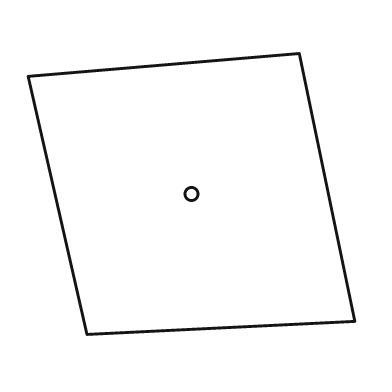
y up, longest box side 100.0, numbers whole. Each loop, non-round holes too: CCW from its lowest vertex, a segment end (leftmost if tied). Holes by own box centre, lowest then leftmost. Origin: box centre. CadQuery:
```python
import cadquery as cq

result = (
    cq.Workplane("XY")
    .moveTo(-32.0, -43.0)
    .lineTo(50.0, -39.0)
    .lineTo(33.0, 43.0)
    .lineTo(-50.0, 36.0)
    .close()
    .moveTo(0.0, 0.0)
    .circle(2.0)
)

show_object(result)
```